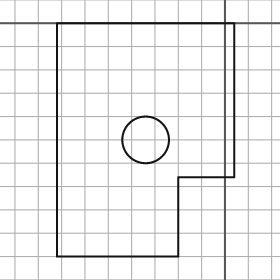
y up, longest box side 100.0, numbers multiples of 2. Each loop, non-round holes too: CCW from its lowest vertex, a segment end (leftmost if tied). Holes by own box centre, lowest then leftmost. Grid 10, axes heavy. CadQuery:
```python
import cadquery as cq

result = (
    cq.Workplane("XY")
    .moveTo(-72.0, -100.0)
    .lineTo(-20.0, -100.0)
    .lineTo(-20.0, -66.0)
    .lineTo(4.0, -66.0)
    .lineTo(4.0, 0.0)
    .lineTo(-72.0, 0.0)
    .close()
    .moveTo(-34.0, -50.0)
    .circle(10.0)
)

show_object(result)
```